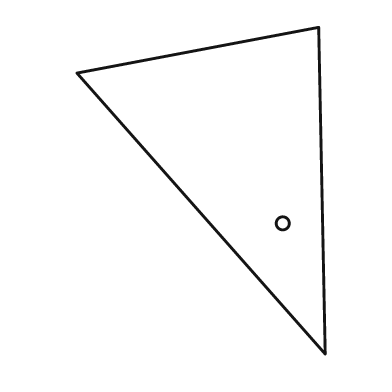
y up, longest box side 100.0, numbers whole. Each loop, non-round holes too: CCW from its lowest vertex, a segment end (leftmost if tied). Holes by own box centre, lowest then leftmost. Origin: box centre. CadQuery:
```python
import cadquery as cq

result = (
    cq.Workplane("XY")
    .moveTo(38.0, -50.0)
    .lineTo(36.0, 50.0)
    .lineTo(-38.0, 36.0)
    .close()
    .moveTo(25.0, -10.0)
    .circle(2.0)
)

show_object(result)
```